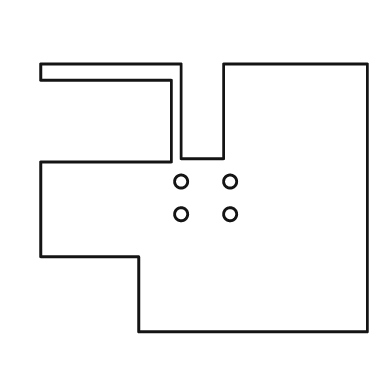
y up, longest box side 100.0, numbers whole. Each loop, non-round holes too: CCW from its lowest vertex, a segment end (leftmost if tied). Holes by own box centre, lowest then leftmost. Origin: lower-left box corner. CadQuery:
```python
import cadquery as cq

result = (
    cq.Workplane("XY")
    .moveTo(30.0, 0.0)
    .lineTo(100.0, 0.0)
    .lineTo(100.0, 82.0)
    .lineTo(56.0, 82.0)
    .lineTo(56.0, 53.0)
    .lineTo(43.0, 53.0)
    .lineTo(43.0, 82.0)
    .lineTo(0.0, 82.0)
    .lineTo(0.0, 77.0)
    .lineTo(40.0, 77.0)
    .lineTo(40.0, 52.0)
    .lineTo(0.0, 52.0)
    .lineTo(0.0, 23.0)
    .lineTo(30.0, 23.0)
    .close()
    .moveTo(43.0, 36.0)
    .circle(2.0)
    .moveTo(58.0, 36.0)
    .circle(2.0)
    .moveTo(43.0, 46.0)
    .circle(2.0)
    .moveTo(58.0, 46.0)
    .circle(2.0)
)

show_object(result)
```